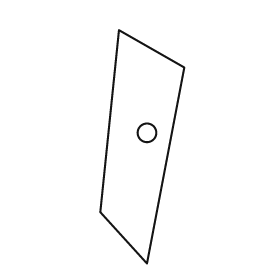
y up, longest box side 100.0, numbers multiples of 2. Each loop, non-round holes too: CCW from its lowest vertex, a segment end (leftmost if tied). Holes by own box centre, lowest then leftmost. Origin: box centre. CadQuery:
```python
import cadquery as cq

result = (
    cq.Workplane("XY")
    .moveTo(2.0, -50.0)
    .lineTo(18.0, 34.0)
    .lineTo(-10.0, 50.0)
    .lineTo(-18.0, -28.0)
    .close()
    .moveTo(2.0, 6.0)
    .circle(4.0)
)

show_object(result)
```